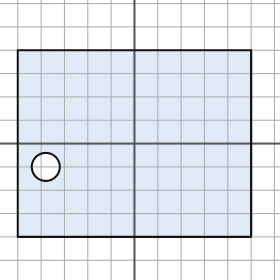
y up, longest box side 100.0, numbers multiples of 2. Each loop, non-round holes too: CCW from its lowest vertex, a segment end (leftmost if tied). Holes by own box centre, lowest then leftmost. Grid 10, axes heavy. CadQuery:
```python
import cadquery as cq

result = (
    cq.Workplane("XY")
    .moveTo(-50.0, -40.0)
    .lineTo(50.0, -40.0)
    .lineTo(50.0, 40.0)
    .lineTo(-50.0, 40.0)
    .close()
    .moveTo(-38.0, -10.0)
    .circle(6.0)
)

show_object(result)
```